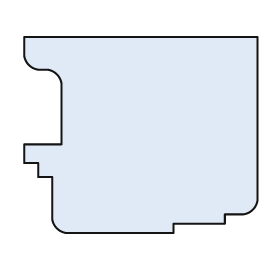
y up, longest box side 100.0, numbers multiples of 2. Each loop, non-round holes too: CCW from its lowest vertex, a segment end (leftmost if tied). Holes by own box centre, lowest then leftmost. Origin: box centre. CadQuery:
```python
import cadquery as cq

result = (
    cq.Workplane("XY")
    .moveTo(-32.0, -42.0)
    .lineTo(14.0, -42.0)
    .lineTo(14.0, -38.0)
    .lineTo(36.0, -38.0)
    .lineTo(36.0, -34.0)
    .lineTo(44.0, -34.0)
    .threePointArc((48.0, -32.0), (50.0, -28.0))
    .lineTo(50.0, 42.0)
    .lineTo(-50.0, 42.0)
    .lineTo(-50.0, 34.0)
    .threePointArc((-48.0, 30.0), (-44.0, 28.0))
    .lineTo(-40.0, 28.0)
    .threePointArc((-36.0, 26.0), (-34.0, 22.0))
    .lineTo(-34.0, -4.0)
    .lineTo(-50.0, -4.0)
    .lineTo(-50.0, -12.0)
    .lineTo(-44.0, -12.0)
    .lineTo(-44.0, -18.0)
    .lineTo(-38.0, -18.0)
    .lineTo(-38.0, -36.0)
    .threePointArc((-36.0, -40.0), (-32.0, -42.0))
    .close()
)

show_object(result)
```